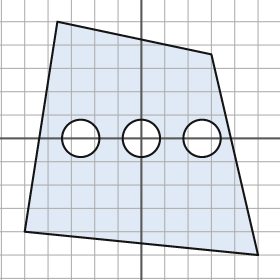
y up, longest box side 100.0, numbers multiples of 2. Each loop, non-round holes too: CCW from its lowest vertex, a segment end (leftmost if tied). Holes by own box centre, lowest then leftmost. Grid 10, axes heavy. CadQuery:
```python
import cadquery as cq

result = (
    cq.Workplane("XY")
    .moveTo(50.0, -50.0)
    .lineTo(30.0, 36.0)
    .lineTo(-36.0, 50.0)
    .lineTo(-50.0, -40.0)
    .close()
    .moveTo(-26.0, 0.0)
    .circle(8.0)
    .moveTo(0.0, 0.0)
    .circle(8.0)
    .moveTo(26.0, 0.0)
    .circle(8.0)
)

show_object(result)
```